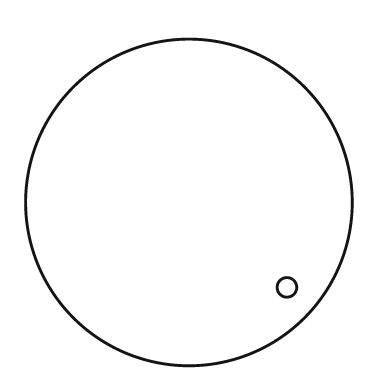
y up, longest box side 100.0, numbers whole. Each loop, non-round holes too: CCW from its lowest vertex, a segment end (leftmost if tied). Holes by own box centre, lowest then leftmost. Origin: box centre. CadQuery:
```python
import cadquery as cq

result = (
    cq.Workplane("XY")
    .moveTo(0.0, 0.0)
    .circle(50.0)
    .moveTo(30.0, -26.0)
    .circle(3.0)
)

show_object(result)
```